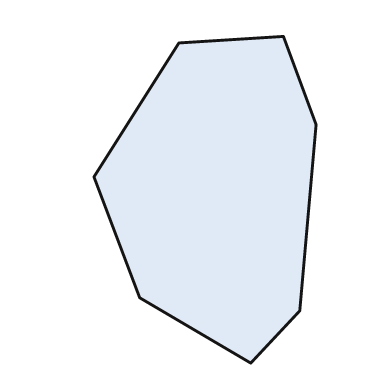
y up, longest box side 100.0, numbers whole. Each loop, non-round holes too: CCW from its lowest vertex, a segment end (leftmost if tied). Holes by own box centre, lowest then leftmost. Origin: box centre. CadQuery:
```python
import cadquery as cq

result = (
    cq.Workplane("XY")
    .moveTo(14.0, -50.0)
    .lineTo(29.0, -34.0)
    .lineTo(34.0, 23.0)
    .lineTo(24.0, 50.0)
    .lineTo(-8.0, 48.0)
    .lineTo(-34.0, 7.0)
    .lineTo(-20.0, -30.0)
    .close()
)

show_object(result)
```